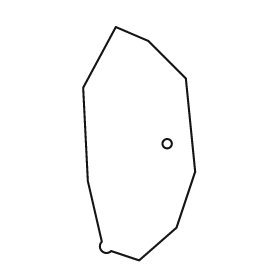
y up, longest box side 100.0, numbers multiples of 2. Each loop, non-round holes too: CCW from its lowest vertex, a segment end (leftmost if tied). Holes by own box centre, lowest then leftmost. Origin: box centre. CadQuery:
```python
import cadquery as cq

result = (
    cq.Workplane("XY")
    .moveTo(0.0, -50.0)
    .lineTo(16.0, -36.0)
    .lineTo(24.0, -12.0)
    .lineTo(20.0, 28.0)
    .lineTo(4.0, 44.0)
    .lineTo(-10.0, 50.0)
    .lineTo(-24.0, 24.0)
    .lineTo(-22.0, -16.0)
    .lineTo(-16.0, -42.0)
    .threePointArc((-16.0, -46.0), (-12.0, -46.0))
    .close()
    .moveTo(12.0, 0.0)
    .circle(2.0)
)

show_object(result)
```